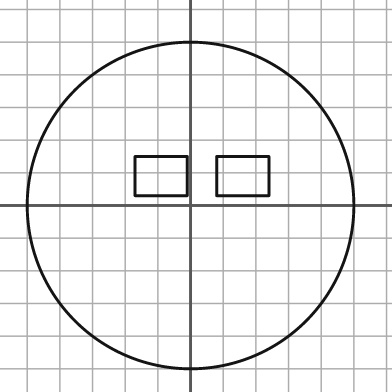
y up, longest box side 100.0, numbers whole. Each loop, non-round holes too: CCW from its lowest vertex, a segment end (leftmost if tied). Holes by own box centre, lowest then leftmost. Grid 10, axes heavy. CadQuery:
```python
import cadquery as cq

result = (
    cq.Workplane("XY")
    .moveTo(0.0, 0.0)
    .circle(50.0)
    .moveTo(-17.0, 3.0)
    .lineTo(-1.0, 3.0)
    .lineTo(-1.0, 15.0)
    .lineTo(-17.0, 15.0)
    .close()
    .moveTo(8.0, 3.0)
    .lineTo(24.0, 3.0)
    .lineTo(24.0, 15.0)
    .lineTo(8.0, 15.0)
    .close()
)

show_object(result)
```